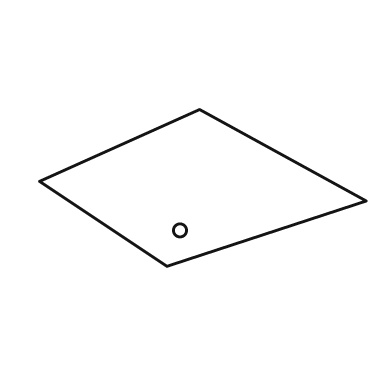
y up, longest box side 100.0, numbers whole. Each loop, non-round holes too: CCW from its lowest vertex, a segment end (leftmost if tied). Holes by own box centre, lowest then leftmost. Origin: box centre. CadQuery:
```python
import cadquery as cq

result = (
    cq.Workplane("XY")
    .moveTo(-11.0, -24.0)
    .lineTo(50.0, -4.0)
    .lineTo(-1.0, 24.0)
    .lineTo(-50.0, 2.0)
    .close()
    .moveTo(-7.0, -13.0)
    .circle(2.0)
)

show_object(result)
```